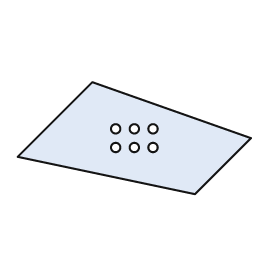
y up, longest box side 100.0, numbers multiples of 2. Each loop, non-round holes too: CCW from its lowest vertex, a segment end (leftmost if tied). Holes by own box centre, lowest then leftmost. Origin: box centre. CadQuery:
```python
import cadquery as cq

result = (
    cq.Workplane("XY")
    .moveTo(26.0, -24.0)
    .lineTo(50.0, 0.0)
    .lineTo(-18.0, 24.0)
    .lineTo(-50.0, -8.0)
    .close()
    .moveTo(-8.0, -4.0)
    .circle(2.0)
    .moveTo(0.0, -4.0)
    .circle(2.0)
    .moveTo(8.0, -4.0)
    .circle(2.0)
    .moveTo(-8.0, 4.0)
    .circle(2.0)
    .moveTo(0.0, 4.0)
    .circle(2.0)
    .moveTo(8.0, 4.0)
    .circle(2.0)
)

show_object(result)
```